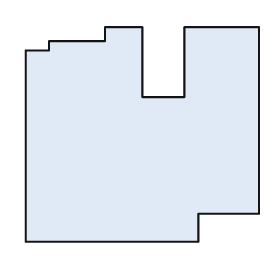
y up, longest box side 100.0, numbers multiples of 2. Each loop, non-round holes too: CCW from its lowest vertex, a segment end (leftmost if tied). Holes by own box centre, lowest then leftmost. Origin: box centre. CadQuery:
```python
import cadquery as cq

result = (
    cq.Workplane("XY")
    .moveTo(-50.0, -46.0)
    .lineTo(24.0, -46.0)
    .lineTo(24.0, -34.0)
    .lineTo(50.0, -34.0)
    .lineTo(50.0, 46.0)
    .lineTo(18.0, 46.0)
    .lineTo(18.0, 16.0)
    .lineTo(0.0, 16.0)
    .lineTo(0.0, 46.0)
    .lineTo(-16.0, 46.0)
    .lineTo(-16.0, 40.0)
    .lineTo(-40.0, 40.0)
    .lineTo(-40.0, 36.0)
    .lineTo(-50.0, 36.0)
    .close()
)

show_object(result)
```